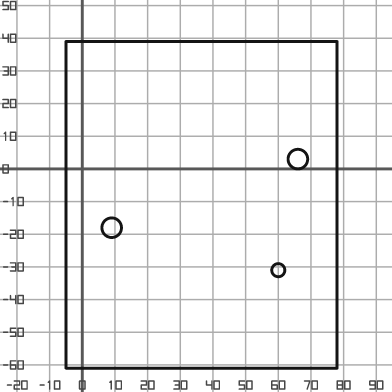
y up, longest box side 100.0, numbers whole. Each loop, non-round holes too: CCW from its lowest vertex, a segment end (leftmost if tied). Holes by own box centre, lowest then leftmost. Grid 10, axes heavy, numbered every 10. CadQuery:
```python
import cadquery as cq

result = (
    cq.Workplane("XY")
    .moveTo(-5.0, -61.0)
    .lineTo(78.0, -61.0)
    .lineTo(78.0, 39.0)
    .lineTo(-5.0, 39.0)
    .close()
    .moveTo(60.0, -31.0)
    .circle(2.0)
    .moveTo(9.0, -18.0)
    .circle(3.0)
    .moveTo(66.0, 3.0)
    .circle(3.0)
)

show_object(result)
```